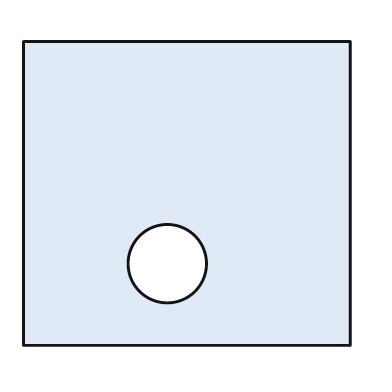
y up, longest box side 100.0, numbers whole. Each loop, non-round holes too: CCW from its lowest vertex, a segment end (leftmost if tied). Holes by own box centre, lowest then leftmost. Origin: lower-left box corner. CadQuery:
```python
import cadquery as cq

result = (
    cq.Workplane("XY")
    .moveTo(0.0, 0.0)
    .lineTo(100.0, 0.0)
    .lineTo(100.0, 93.0)
    .lineTo(0.0, 93.0)
    .close()
    .moveTo(44.0, 25.0)
    .circle(12.0)
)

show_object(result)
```